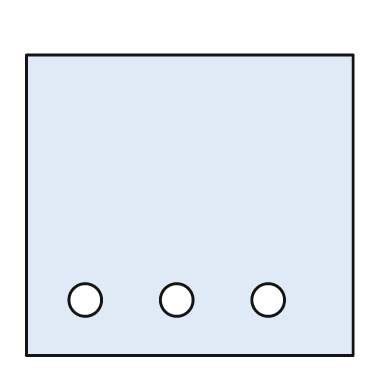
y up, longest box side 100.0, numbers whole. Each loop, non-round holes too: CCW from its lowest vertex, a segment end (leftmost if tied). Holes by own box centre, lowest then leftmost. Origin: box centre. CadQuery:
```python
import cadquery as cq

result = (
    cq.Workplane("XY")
    .moveTo(-50.0, -46.0)
    .lineTo(50.0, -46.0)
    .lineTo(50.0, 46.0)
    .lineTo(-50.0, 46.0)
    .close()
    .moveTo(-32.0, -29.0)
    .circle(5.0)
    .moveTo(-4.0, -29.0)
    .circle(5.0)
    .moveTo(24.0, -29.0)
    .circle(5.0)
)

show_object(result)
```